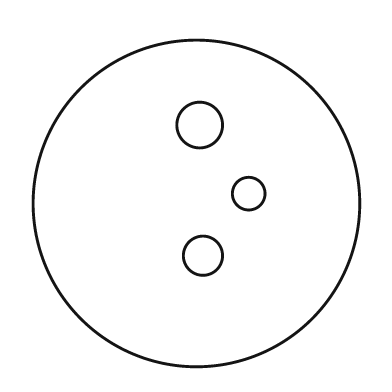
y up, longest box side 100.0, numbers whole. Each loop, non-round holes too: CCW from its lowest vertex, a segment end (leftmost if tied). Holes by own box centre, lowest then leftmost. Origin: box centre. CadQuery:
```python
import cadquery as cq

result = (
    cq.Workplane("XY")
    .moveTo(0.0, 0.0)
    .circle(50.0)
    .moveTo(2.0, -16.0)
    .circle(6.0)
    .moveTo(16.0, 3.0)
    .circle(5.0)
    .moveTo(1.0, 24.0)
    .circle(7.0)
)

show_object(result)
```